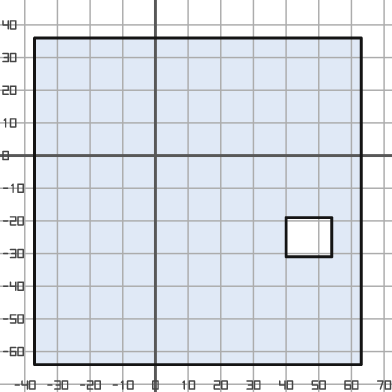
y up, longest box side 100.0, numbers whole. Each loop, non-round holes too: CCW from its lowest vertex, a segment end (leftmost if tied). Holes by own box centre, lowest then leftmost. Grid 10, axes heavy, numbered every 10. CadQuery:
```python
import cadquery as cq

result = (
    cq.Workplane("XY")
    .moveTo(-37.0, -64.0)
    .lineTo(63.0, -64.0)
    .lineTo(63.0, 36.0)
    .lineTo(-37.0, 36.0)
    .close()
    .moveTo(40.0, -31.0)
    .lineTo(54.0, -31.0)
    .lineTo(54.0, -19.0)
    .lineTo(40.0, -19.0)
    .close()
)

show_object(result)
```